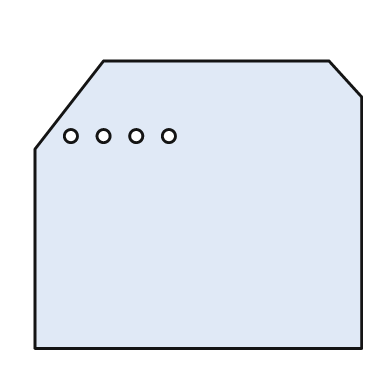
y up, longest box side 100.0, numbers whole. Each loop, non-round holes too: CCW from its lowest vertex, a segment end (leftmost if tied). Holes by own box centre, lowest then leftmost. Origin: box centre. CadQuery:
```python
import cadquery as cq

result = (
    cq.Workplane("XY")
    .moveTo(-50.0, -44.0)
    .lineTo(50.0, -44.0)
    .lineTo(50.0, 33.0)
    .lineTo(40.0, 44.0)
    .lineTo(-29.0, 44.0)
    .lineTo(-50.0, 17.0)
    .close()
    .moveTo(-39.0, 21.0)
    .circle(2.0)
    .moveTo(-29.0, 21.0)
    .circle(2.0)
    .moveTo(-19.0, 21.0)
    .circle(2.0)
    .moveTo(-9.0, 21.0)
    .circle(2.0)
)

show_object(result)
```